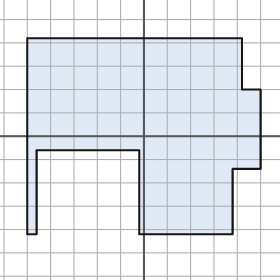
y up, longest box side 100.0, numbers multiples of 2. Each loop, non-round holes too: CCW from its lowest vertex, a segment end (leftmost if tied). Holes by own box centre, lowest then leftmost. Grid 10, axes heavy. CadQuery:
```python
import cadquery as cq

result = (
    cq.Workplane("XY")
    .moveTo(-50.0, -42.0)
    .lineTo(-46.0, -42.0)
    .lineTo(-46.0, -6.0)
    .lineTo(-2.0, -6.0)
    .lineTo(-2.0, -42.0)
    .lineTo(38.0, -42.0)
    .lineTo(38.0, -14.0)
    .lineTo(50.0, -14.0)
    .lineTo(50.0, 20.0)
    .lineTo(42.0, 20.0)
    .lineTo(42.0, 42.0)
    .lineTo(-50.0, 42.0)
    .close()
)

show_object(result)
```